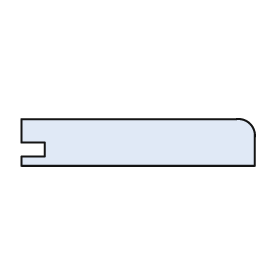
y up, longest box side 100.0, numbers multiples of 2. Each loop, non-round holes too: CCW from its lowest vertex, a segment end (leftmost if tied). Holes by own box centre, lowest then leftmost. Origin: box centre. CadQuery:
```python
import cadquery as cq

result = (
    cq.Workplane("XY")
    .moveTo(-50.0, -10.0)
    .lineTo(50.0, -10.0)
    .lineTo(50.0, 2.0)
    .threePointArc((48.0, 8.0), (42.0, 10.0))
    .lineTo(-50.0, 10.0)
    .lineTo(-50.0, 0.0)
    .lineTo(-40.0, 0.0)
    .lineTo(-40.0, -6.0)
    .lineTo(-50.0, -6.0)
    .close()
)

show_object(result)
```